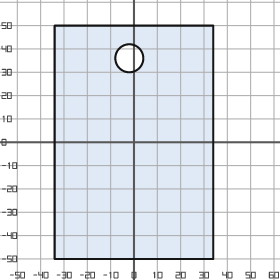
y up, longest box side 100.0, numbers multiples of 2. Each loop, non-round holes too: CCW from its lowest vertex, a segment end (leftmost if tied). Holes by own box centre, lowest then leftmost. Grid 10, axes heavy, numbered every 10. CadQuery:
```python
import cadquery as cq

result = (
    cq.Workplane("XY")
    .moveTo(-34.0, -50.0)
    .lineTo(34.0, -50.0)
    .lineTo(34.0, 50.0)
    .lineTo(-34.0, 50.0)
    .close()
    .moveTo(-2.0, 36.0)
    .circle(6.0)
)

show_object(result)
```